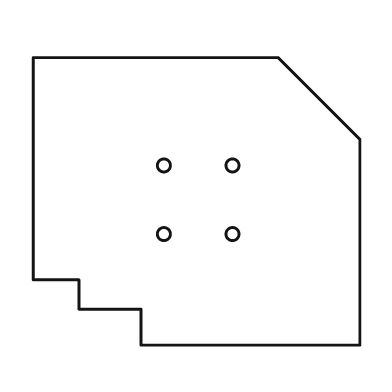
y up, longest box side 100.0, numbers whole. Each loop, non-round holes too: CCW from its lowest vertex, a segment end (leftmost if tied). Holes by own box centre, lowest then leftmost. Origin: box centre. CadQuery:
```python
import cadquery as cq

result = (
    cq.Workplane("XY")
    .moveTo(-17.0, -44.0)
    .lineTo(50.0, -44.0)
    .lineTo(50.0, 19.0)
    .lineTo(25.0, 44.0)
    .lineTo(-50.0, 44.0)
    .lineTo(-50.0, -24.0)
    .lineTo(-36.0, -24.0)
    .lineTo(-36.0, -33.0)
    .lineTo(-17.0, -33.0)
    .close()
    .moveTo(-10.0, -10.0)
    .circle(2.0)
    .moveTo(11.0, -10.0)
    .circle(2.0)
    .moveTo(-10.0, 11.0)
    .circle(2.0)
    .moveTo(11.0, 11.0)
    .circle(2.0)
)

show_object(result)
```